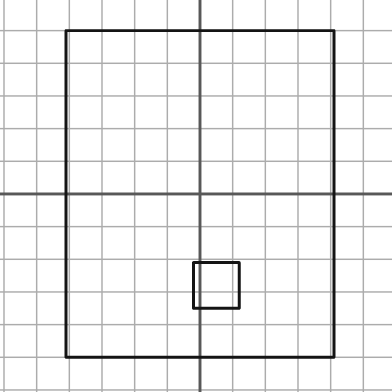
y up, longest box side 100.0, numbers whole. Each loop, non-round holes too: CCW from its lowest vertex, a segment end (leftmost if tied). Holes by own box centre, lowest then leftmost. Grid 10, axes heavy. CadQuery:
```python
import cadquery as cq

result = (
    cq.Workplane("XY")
    .moveTo(-41.0, -50.0)
    .lineTo(41.0, -50.0)
    .lineTo(41.0, 50.0)
    .lineTo(-41.0, 50.0)
    .close()
    .moveTo(-2.0, -35.0)
    .lineTo(12.0, -35.0)
    .lineTo(12.0, -21.0)
    .lineTo(-2.0, -21.0)
    .close()
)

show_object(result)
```